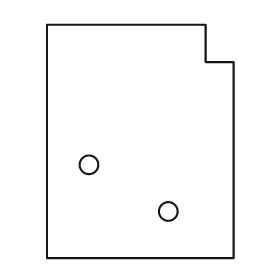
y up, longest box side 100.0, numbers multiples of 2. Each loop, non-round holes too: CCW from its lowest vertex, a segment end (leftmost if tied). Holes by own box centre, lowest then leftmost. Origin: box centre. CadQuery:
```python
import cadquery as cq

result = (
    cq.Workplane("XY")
    .moveTo(-40.0, -50.0)
    .lineTo(40.0, -50.0)
    .lineTo(40.0, 34.0)
    .lineTo(28.0, 34.0)
    .lineTo(28.0, 50.0)
    .lineTo(-40.0, 50.0)
    .close()
    .moveTo(12.0, -30.0)
    .circle(4.0)
    .moveTo(-22.0, -10.0)
    .circle(4.0)
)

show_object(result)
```